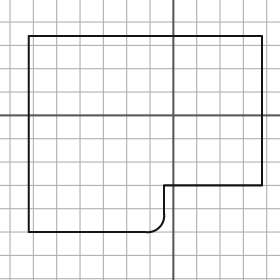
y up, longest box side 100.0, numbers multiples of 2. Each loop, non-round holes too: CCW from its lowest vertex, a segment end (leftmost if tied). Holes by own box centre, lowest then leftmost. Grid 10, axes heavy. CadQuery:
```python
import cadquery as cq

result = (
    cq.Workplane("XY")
    .moveTo(-62.0, -50.0)
    .lineTo(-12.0, -50.0)
    .threePointArc((-6.0, -48.0), (-4.0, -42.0))
    .lineTo(-4.0, -30.0)
    .lineTo(38.0, -30.0)
    .lineTo(38.0, 34.0)
    .lineTo(-62.0, 34.0)
    .close()
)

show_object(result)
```